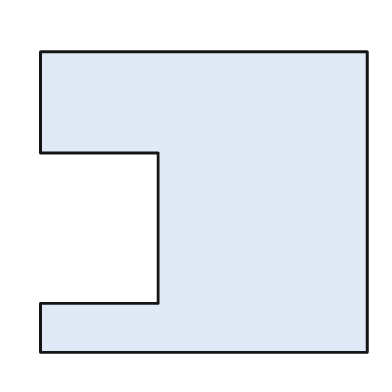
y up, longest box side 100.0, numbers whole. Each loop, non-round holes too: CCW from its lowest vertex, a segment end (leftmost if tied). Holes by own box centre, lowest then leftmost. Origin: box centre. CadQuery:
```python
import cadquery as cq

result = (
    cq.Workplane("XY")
    .moveTo(-50.0, -46.0)
    .lineTo(50.0, -46.0)
    .lineTo(50.0, 46.0)
    .lineTo(-50.0, 46.0)
    .lineTo(-50.0, 15.0)
    .lineTo(-14.0, 15.0)
    .lineTo(-14.0, -31.0)
    .lineTo(-50.0, -31.0)
    .close()
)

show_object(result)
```